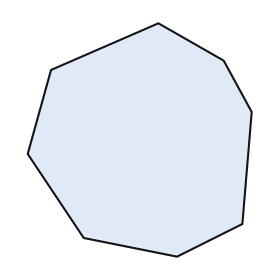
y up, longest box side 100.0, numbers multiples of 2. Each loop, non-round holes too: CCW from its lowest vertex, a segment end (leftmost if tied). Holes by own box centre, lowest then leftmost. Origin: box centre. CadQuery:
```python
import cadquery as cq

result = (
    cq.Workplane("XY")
    .moveTo(16.0, -50.0)
    .lineTo(44.0, -36.0)
    .lineTo(48.0, 12.0)
    .lineTo(36.0, 34.0)
    .lineTo(8.0, 50.0)
    .lineTo(-38.0, 30.0)
    .lineTo(-48.0, -6.0)
    .lineTo(-24.0, -42.0)
    .close()
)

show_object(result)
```